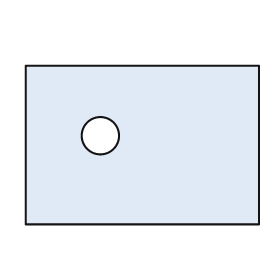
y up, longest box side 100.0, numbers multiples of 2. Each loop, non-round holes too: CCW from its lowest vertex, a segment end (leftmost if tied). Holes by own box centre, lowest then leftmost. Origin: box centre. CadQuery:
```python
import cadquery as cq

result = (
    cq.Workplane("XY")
    .moveTo(-50.0, -34.0)
    .lineTo(50.0, -34.0)
    .lineTo(50.0, 34.0)
    .lineTo(-50.0, 34.0)
    .close()
    .moveTo(-18.0, 4.0)
    .circle(8.0)
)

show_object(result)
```